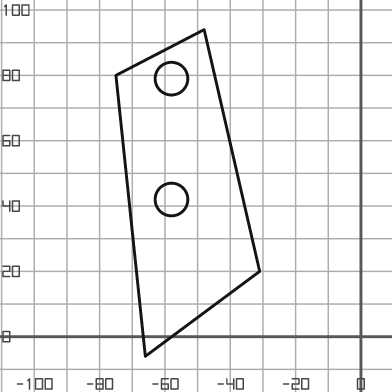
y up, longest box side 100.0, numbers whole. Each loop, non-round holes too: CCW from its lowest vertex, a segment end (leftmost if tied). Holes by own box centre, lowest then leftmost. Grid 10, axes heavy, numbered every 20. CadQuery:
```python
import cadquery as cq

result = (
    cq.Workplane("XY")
    .moveTo(-66.0, -6.0)
    .lineTo(-31.0, 20.0)
    .lineTo(-48.0, 94.0)
    .lineTo(-75.0, 80.0)
    .close()
    .moveTo(-58.0, 42.0)
    .circle(5.0)
    .moveTo(-58.0, 79.0)
    .circle(5.0)
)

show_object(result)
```